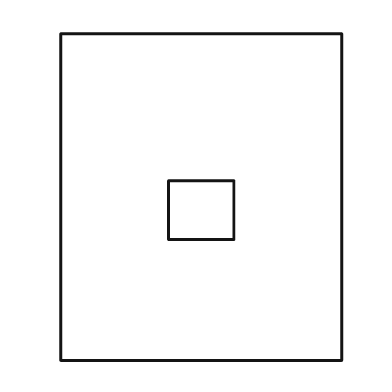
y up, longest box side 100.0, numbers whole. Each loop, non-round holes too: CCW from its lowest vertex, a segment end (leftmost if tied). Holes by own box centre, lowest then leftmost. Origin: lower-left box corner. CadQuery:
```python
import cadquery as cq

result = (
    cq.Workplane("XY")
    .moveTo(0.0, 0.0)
    .lineTo(86.0, 0.0)
    .lineTo(86.0, 100.0)
    .lineTo(0.0, 100.0)
    .close()
    .moveTo(33.0, 37.0)
    .lineTo(53.0, 37.0)
    .lineTo(53.0, 55.0)
    .lineTo(33.0, 55.0)
    .close()
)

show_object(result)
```